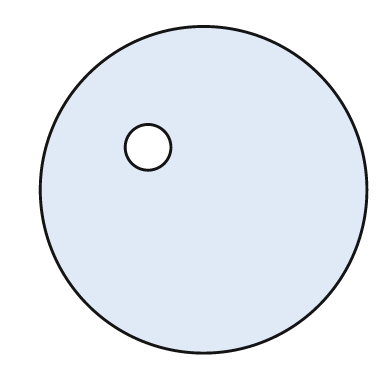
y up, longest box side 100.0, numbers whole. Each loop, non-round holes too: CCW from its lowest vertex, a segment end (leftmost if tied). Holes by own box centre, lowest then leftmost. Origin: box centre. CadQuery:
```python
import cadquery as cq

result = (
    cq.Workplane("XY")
    .moveTo(0.0, 0.0)
    .circle(50.0)
    .moveTo(-17.0, 13.0)
    .circle(7.0)
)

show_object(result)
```